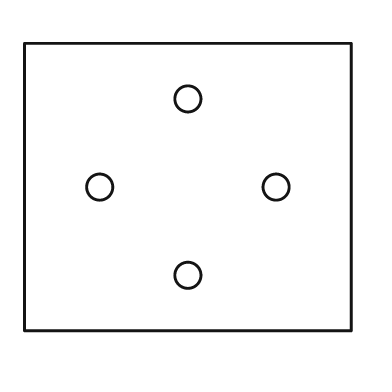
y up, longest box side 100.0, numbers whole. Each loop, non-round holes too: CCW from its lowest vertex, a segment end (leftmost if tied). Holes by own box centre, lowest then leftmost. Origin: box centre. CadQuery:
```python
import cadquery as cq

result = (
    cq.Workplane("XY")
    .moveTo(-50.0, -44.0)
    .lineTo(50.0, -44.0)
    .lineTo(50.0, 44.0)
    .lineTo(-50.0, 44.0)
    .close()
    .moveTo(0.0, -27.0)
    .circle(4.0)
    .moveTo(-27.0, 0.0)
    .circle(4.0)
    .moveTo(27.0, 0.0)
    .circle(4.0)
    .moveTo(0.0, 27.0)
    .circle(4.0)
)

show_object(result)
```